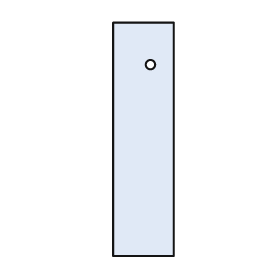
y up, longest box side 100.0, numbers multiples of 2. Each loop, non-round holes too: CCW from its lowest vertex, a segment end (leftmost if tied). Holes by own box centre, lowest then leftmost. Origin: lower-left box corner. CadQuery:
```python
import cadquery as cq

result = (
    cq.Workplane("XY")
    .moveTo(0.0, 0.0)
    .lineTo(26.0, 0.0)
    .lineTo(26.0, 100.0)
    .lineTo(0.0, 100.0)
    .close()
    .moveTo(16.0, 82.0)
    .circle(2.0)
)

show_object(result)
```